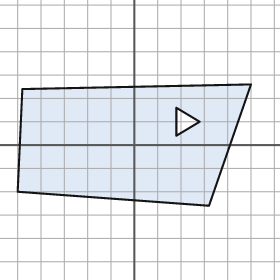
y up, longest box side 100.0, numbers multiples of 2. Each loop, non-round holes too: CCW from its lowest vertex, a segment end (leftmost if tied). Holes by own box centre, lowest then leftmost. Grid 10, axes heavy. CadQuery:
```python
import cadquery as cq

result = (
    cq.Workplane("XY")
    .moveTo(32.0, -26.0)
    .lineTo(50.0, 26.0)
    .lineTo(-48.0, 24.0)
    .lineTo(-50.0, -20.0)
    .close()
    .moveTo(18.0, 4.0)
    .lineTo(28.0, 10.0)
    .lineTo(18.0, 16.0)
    .close()
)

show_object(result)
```